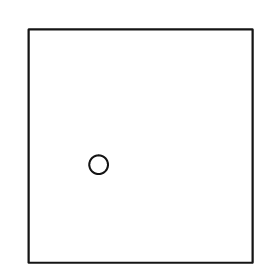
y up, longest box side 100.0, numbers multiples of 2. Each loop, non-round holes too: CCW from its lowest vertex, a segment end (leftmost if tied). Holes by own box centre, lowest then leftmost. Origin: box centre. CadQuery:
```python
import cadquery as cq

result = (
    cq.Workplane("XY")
    .moveTo(-48.0, -50.0)
    .lineTo(48.0, -50.0)
    .lineTo(48.0, 50.0)
    .lineTo(-48.0, 50.0)
    .close()
    .moveTo(-18.0, -8.0)
    .circle(4.0)
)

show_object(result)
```